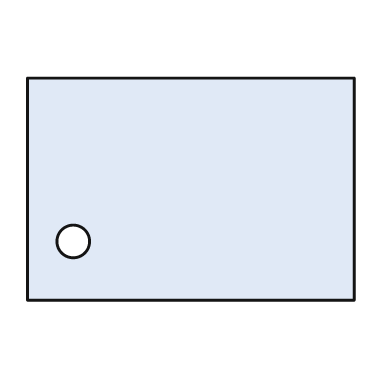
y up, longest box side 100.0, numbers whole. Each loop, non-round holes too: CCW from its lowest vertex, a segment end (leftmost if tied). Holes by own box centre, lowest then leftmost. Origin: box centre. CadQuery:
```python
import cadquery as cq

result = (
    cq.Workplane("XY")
    .moveTo(-50.0, -34.0)
    .lineTo(50.0, -34.0)
    .lineTo(50.0, 34.0)
    .lineTo(-50.0, 34.0)
    .close()
    .moveTo(-36.0, -16.0)
    .circle(5.0)
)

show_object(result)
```